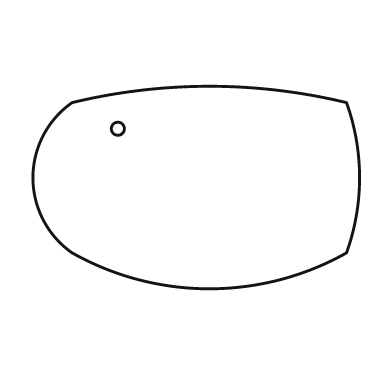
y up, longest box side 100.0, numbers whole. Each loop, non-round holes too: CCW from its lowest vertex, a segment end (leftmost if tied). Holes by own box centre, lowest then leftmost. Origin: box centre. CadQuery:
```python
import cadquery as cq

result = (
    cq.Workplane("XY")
    .moveTo(-38.0, -20.0)
    .threePointArc((4.0, -31.0), (46.0, -20.0))
    .threePointArc((50.0, 3.0), (46.0, 26.0))
    .threePointArc((4.0, 31.0), (-38.0, 26.0))
    .threePointArc((-50.0, 3.0), (-38.0, -20.0))
    .close()
    .moveTo(-24.0, 18.0)
    .circle(2.0)
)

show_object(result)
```